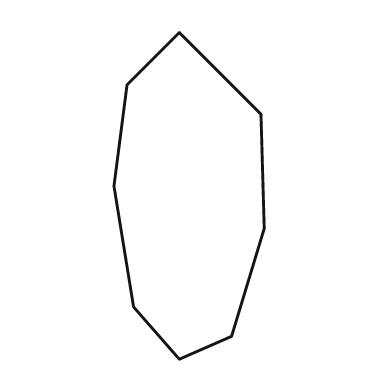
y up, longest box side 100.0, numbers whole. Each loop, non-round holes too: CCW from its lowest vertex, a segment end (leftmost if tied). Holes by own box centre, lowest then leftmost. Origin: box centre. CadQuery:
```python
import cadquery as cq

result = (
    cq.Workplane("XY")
    .moveTo(-3.0, -50.0)
    .lineTo(13.0, -43.0)
    .lineTo(23.0, -10.0)
    .lineTo(22.0, 25.0)
    .lineTo(-3.0, 50.0)
    .lineTo(-19.0, 34.0)
    .lineTo(-23.0, 3.0)
    .lineTo(-17.0, -34.0)
    .close()
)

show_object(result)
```